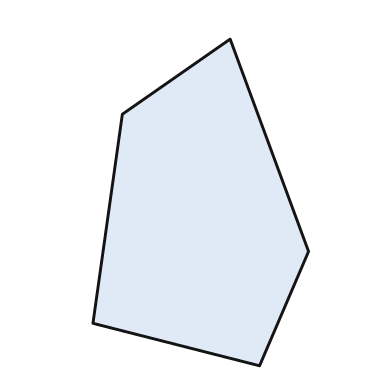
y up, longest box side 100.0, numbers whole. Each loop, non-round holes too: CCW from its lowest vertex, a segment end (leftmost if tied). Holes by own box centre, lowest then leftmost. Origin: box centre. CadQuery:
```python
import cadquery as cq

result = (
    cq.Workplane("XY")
    .moveTo(18.0, -50.0)
    .lineTo(33.0, -15.0)
    .lineTo(9.0, 50.0)
    .lineTo(-24.0, 27.0)
    .lineTo(-33.0, -37.0)
    .close()
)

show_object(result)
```